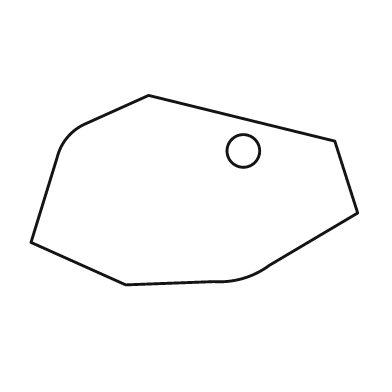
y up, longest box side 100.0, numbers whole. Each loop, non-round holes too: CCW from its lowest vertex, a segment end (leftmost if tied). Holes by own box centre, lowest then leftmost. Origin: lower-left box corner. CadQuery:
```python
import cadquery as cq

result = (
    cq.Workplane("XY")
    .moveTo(29.0, 0.0)
    .lineTo(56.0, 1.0)
    .threePointArc((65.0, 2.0), (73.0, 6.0))
    .lineTo(100.0, 22.0)
    .lineTo(93.0, 44.0)
    .lineTo(36.0, 58.0)
    .lineTo(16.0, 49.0)
    .threePointArc((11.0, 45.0), (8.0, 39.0))
    .lineTo(0.0, 13.0)
    .close()
    .moveTo(65.0, 41.0)
    .circle(5.0)
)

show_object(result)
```